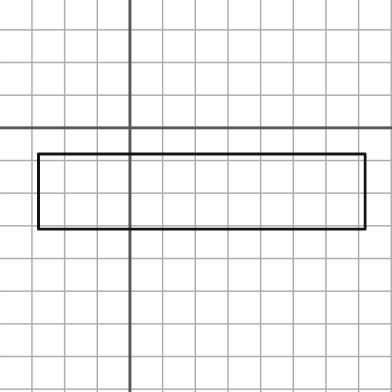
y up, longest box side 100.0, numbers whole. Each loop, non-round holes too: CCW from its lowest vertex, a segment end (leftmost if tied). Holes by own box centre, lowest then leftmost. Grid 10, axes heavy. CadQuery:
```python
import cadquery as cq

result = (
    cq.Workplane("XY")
    .moveTo(-28.0, -31.0)
    .lineTo(72.0, -31.0)
    .lineTo(72.0, -8.0)
    .lineTo(-28.0, -8.0)
    .close()
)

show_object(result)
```